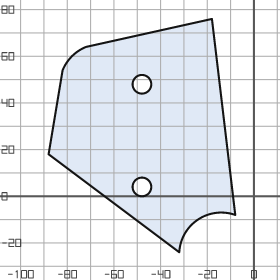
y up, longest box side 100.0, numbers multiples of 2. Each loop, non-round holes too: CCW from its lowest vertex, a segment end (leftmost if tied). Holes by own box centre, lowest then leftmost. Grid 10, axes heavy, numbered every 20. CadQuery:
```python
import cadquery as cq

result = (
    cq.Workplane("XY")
    .moveTo(-32.0, -24.0)
    .threePointArc((-24.0, -10.0), (-8.0, -8.0))
    .lineTo(-18.0, 76.0)
    .lineTo(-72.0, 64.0)
    .threePointArc((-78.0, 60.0), (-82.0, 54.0))
    .lineTo(-88.0, 18.0)
    .close()
    .moveTo(-48.0, 4.0)
    .circle(4.0)
    .moveTo(-48.0, 48.0)
    .circle(4.0)
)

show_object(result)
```